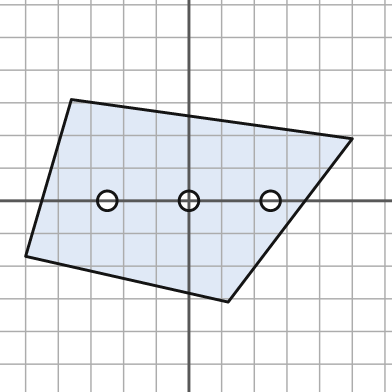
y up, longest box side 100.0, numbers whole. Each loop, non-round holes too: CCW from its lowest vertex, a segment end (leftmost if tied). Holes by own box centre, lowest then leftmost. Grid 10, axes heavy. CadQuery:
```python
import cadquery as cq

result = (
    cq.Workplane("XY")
    .moveTo(12.0, -31.0)
    .lineTo(50.0, 19.0)
    .lineTo(-36.0, 31.0)
    .lineTo(-50.0, -17.0)
    .close()
    .moveTo(-25.0, 0.0)
    .circle(3.0)
    .moveTo(0.0, 0.0)
    .circle(3.0)
    .moveTo(25.0, 0.0)
    .circle(3.0)
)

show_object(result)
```